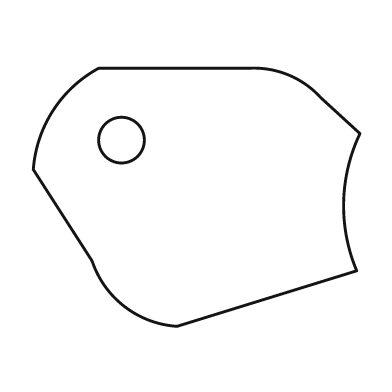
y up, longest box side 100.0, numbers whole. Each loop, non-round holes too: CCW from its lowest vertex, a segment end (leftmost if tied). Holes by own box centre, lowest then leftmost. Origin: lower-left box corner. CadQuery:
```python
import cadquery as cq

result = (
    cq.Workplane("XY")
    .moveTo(44.0, 0.0)
    .lineTo(99.0, 17.0)
    .threePointArc((95.0, 38.0), (100.0, 59.0))
    .lineTo(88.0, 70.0)
    .threePointArc((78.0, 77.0), (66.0, 79.0))
    .lineTo(20.0, 79.0)
    .threePointArc((6.0, 66.0), (0.0, 48.0))
    .lineTo(18.0, 20.0)
    .threePointArc((28.0, 6.0), (44.0, 0.0))
    .close()
    .moveTo(27.0, 57.0)
    .circle(7.0)
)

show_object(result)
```